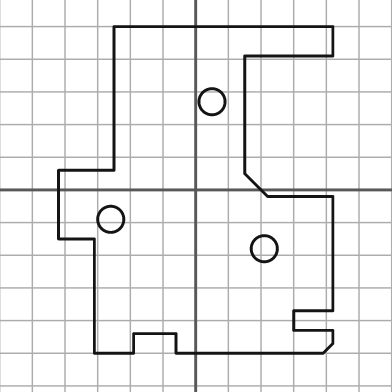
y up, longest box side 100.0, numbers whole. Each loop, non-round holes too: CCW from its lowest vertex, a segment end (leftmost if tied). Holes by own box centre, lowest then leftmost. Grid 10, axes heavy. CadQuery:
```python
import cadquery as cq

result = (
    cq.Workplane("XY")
    .moveTo(-31.0, -50.0)
    .lineTo(-19.0, -50.0)
    .lineTo(-19.0, -44.0)
    .lineTo(-6.0, -44.0)
    .lineTo(-6.0, -50.0)
    .lineTo(39.0, -50.0)
    .lineTo(42.0, -47.0)
    .lineTo(42.0, -43.0)
    .lineTo(30.0, -43.0)
    .lineTo(30.0, -37.0)
    .lineTo(42.0, -37.0)
    .lineTo(42.0, -2.0)
    .lineTo(22.0, -2.0)
    .lineTo(15.0, 5.0)
    .lineTo(15.0, 41.0)
    .lineTo(42.0, 41.0)
    .lineTo(42.0, 50.0)
    .lineTo(-25.0, 50.0)
    .lineTo(-25.0, 6.0)
    .lineTo(-42.0, 6.0)
    .lineTo(-42.0, -15.0)
    .lineTo(-31.0, -15.0)
    .close()
    .moveTo(21.0, -18.0)
    .circle(4.0)
    .moveTo(-26.0, -9.0)
    .circle(4.0)
    .moveTo(5.0, 27.0)
    .circle(4.0)
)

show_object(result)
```